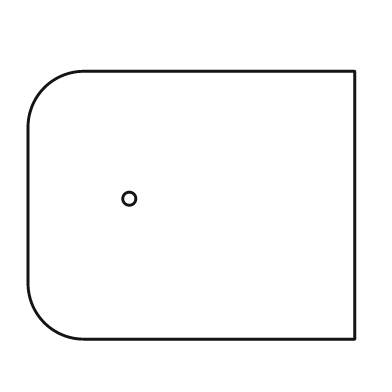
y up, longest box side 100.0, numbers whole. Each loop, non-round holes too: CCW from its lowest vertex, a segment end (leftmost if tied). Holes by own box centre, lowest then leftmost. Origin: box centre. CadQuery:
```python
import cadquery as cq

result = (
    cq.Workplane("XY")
    .moveTo(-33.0, -41.0)
    .lineTo(50.0, -41.0)
    .lineTo(50.0, 41.0)
    .lineTo(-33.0, 41.0)
    .threePointArc((-45.0, 36.0), (-50.0, 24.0))
    .lineTo(-50.0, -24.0)
    .threePointArc((-45.0, -36.0), (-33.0, -41.0))
    .close()
    .moveTo(-19.0, 2.0)
    .circle(2.0)
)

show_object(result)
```